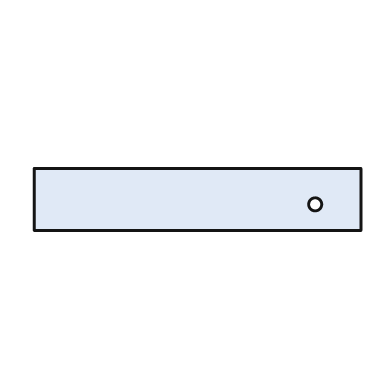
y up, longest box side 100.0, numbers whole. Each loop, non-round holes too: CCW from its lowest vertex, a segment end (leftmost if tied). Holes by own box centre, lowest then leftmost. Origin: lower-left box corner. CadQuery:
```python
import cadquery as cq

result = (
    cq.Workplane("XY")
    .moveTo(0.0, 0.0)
    .lineTo(100.0, 0.0)
    .lineTo(100.0, 19.0)
    .lineTo(0.0, 19.0)
    .close()
    .moveTo(86.0, 8.0)
    .circle(2.0)
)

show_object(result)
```